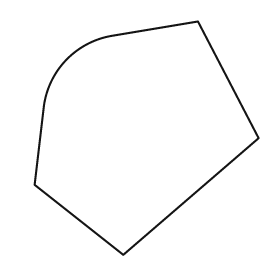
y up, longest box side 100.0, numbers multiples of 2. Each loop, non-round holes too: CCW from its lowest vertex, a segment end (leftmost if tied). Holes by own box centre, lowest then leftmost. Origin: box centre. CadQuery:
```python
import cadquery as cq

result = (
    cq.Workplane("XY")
    .moveTo(-10.0, -50.0)
    .lineTo(48.0, 0.0)
    .lineTo(22.0, 50.0)
    .lineTo(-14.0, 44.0)
    .threePointArc((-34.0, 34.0), (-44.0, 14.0))
    .lineTo(-48.0, -20.0)
    .close()
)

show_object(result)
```